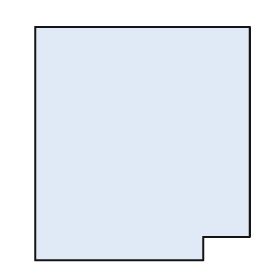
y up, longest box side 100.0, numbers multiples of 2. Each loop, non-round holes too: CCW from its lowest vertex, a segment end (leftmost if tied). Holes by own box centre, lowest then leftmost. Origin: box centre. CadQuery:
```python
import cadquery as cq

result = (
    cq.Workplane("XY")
    .moveTo(-46.0, -50.0)
    .lineTo(26.0, -50.0)
    .lineTo(26.0, -40.0)
    .lineTo(46.0, -40.0)
    .lineTo(46.0, 50.0)
    .lineTo(-46.0, 50.0)
    .close()
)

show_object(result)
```